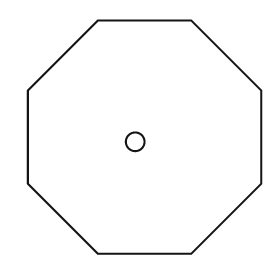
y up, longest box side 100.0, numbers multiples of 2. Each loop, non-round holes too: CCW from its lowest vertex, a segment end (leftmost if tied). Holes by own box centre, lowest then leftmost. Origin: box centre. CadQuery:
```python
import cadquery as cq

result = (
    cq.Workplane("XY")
    .moveTo(-20.0, -50.0)
    .lineTo(20.0, -50.0)
    .lineTo(50.0, -20.0)
    .lineTo(50.0, 20.0)
    .lineTo(20.0, 50.0)
    .lineTo(-20.0, 50.0)
    .lineTo(-50.0, 20.0)
    .lineTo(-50.0, -20.0)
    .close()
    .moveTo(-4.0, -2.0)
    .circle(4.0)
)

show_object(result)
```